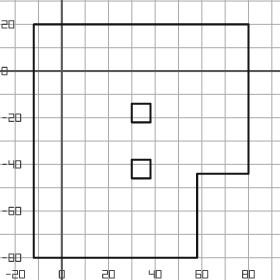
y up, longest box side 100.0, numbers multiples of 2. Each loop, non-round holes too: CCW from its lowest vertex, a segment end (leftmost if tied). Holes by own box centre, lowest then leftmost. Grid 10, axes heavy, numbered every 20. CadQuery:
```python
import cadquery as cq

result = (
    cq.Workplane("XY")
    .moveTo(-12.0, -80.0)
    .lineTo(58.0, -80.0)
    .lineTo(58.0, -44.0)
    .lineTo(80.0, -44.0)
    .lineTo(80.0, 20.0)
    .lineTo(-12.0, 20.0)
    .close()
    .moveTo(30.0, -46.0)
    .lineTo(38.0, -46.0)
    .lineTo(38.0, -38.0)
    .lineTo(30.0, -38.0)
    .close()
    .moveTo(30.0, -22.0)
    .lineTo(38.0, -22.0)
    .lineTo(38.0, -14.0)
    .lineTo(30.0, -14.0)
    .close()
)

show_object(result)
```